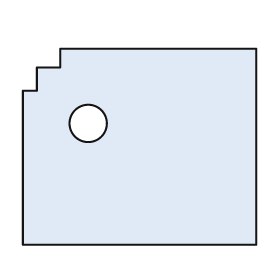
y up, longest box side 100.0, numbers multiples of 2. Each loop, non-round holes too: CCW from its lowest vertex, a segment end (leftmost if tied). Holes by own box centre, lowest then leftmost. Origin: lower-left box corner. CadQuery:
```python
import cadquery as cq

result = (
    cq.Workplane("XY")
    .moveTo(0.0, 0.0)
    .lineTo(100.0, 0.0)
    .lineTo(100.0, 84.0)
    .lineTo(16.0, 84.0)
    .lineTo(16.0, 76.0)
    .lineTo(6.0, 76.0)
    .lineTo(6.0, 66.0)
    .lineTo(0.0, 66.0)
    .close()
    .moveTo(28.0, 52.0)
    .circle(8.0)
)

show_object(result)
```